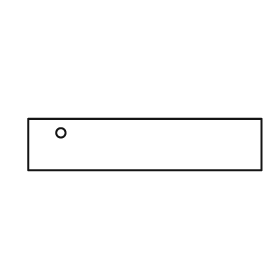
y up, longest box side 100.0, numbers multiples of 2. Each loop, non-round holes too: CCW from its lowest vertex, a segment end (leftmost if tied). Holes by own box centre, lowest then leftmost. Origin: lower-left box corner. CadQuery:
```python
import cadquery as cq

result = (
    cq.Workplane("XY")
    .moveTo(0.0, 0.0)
    .lineTo(100.0, 0.0)
    .lineTo(100.0, 22.0)
    .lineTo(0.0, 22.0)
    .close()
    .moveTo(14.0, 16.0)
    .circle(2.0)
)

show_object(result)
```